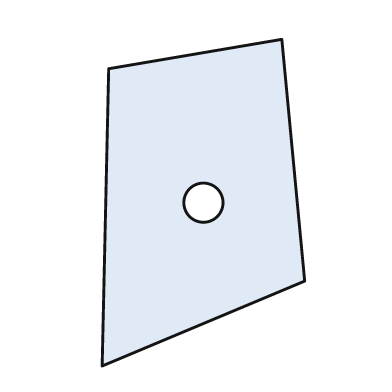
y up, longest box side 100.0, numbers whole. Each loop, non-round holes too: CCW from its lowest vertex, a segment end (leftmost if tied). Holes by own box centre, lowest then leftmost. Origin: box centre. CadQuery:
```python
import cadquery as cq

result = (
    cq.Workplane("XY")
    .moveTo(-31.0, -50.0)
    .lineTo(31.0, -24.0)
    .lineTo(24.0, 50.0)
    .lineTo(-29.0, 41.0)
    .close()
    .moveTo(0.0, 0.0)
    .circle(6.0)
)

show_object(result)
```